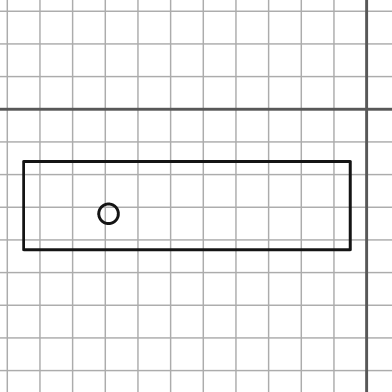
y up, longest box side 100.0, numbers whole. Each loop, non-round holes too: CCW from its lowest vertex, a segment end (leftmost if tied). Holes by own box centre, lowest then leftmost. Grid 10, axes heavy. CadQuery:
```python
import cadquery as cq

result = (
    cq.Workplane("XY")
    .moveTo(-105.0, -43.0)
    .lineTo(-5.0, -43.0)
    .lineTo(-5.0, -16.0)
    .lineTo(-105.0, -16.0)
    .close()
    .moveTo(-79.0, -32.0)
    .circle(3.0)
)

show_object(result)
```